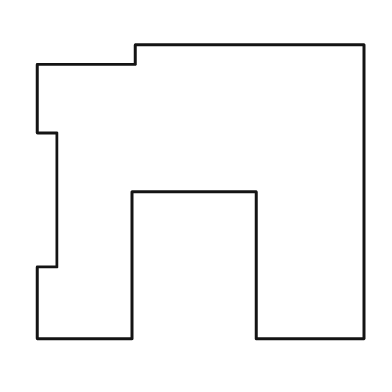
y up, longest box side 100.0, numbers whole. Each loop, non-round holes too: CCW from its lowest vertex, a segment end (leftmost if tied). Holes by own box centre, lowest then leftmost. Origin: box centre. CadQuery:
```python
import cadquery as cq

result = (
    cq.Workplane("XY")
    .moveTo(-50.0, -45.0)
    .lineTo(-21.0, -45.0)
    .lineTo(-21.0, 0.0)
    .lineTo(17.0, 0.0)
    .lineTo(17.0, -45.0)
    .lineTo(50.0, -45.0)
    .lineTo(50.0, 45.0)
    .lineTo(-20.0, 45.0)
    .lineTo(-20.0, 39.0)
    .lineTo(-50.0, 39.0)
    .lineTo(-50.0, 18.0)
    .lineTo(-44.0, 18.0)
    .lineTo(-44.0, -23.0)
    .lineTo(-50.0, -23.0)
    .close()
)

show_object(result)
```